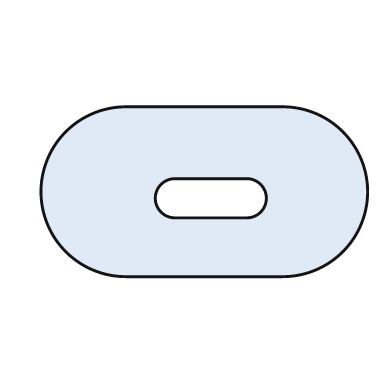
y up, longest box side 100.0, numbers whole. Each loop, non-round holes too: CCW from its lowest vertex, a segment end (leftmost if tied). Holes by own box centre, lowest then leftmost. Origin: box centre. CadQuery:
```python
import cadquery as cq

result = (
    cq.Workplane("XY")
    .moveTo(-24.0, -26.0)
    .lineTo(24.0, -26.0)
    .threePointArc((50.0, 0.0), (24.0, 26.0))
    .lineTo(-24.0, 26.0)
    .threePointArc((-50.0, 0.0), (-24.0, -26.0))
    .close()
    .moveTo(-9.0, -8.0)
    .lineTo(13.0, -8.0)
    .threePointArc((19.0, -2.0), (13.0, 4.0))
    .lineTo(-9.0, 4.0)
    .threePointArc((-15.0, -2.0), (-9.0, -8.0))
    .close()
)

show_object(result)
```